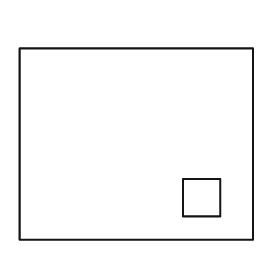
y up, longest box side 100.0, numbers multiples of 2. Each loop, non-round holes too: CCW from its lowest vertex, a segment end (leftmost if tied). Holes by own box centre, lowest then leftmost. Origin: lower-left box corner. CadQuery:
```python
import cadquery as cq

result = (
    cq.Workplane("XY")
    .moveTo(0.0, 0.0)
    .lineTo(100.0, 0.0)
    .lineTo(100.0, 82.0)
    .lineTo(0.0, 82.0)
    .close()
    .moveTo(70.0, 10.0)
    .lineTo(86.0, 10.0)
    .lineTo(86.0, 26.0)
    .lineTo(70.0, 26.0)
    .close()
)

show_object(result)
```